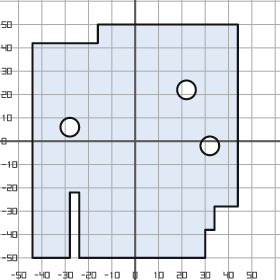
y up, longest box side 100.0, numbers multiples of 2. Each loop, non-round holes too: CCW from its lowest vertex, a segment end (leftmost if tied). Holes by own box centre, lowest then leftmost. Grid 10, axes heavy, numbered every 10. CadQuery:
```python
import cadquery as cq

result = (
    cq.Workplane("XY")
    .moveTo(-44.0, -50.0)
    .lineTo(-28.0, -50.0)
    .lineTo(-28.0, -22.0)
    .lineTo(-24.0, -22.0)
    .lineTo(-24.0, -50.0)
    .lineTo(30.0, -50.0)
    .lineTo(30.0, -38.0)
    .lineTo(34.0, -38.0)
    .lineTo(34.0, -28.0)
    .lineTo(44.0, -28.0)
    .lineTo(44.0, 50.0)
    .lineTo(-16.0, 50.0)
    .lineTo(-16.0, 42.0)
    .lineTo(-44.0, 42.0)
    .close()
    .moveTo(32.0, -2.0)
    .circle(4.0)
    .moveTo(-28.0, 6.0)
    .circle(4.0)
    .moveTo(22.0, 22.0)
    .circle(4.0)
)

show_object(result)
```